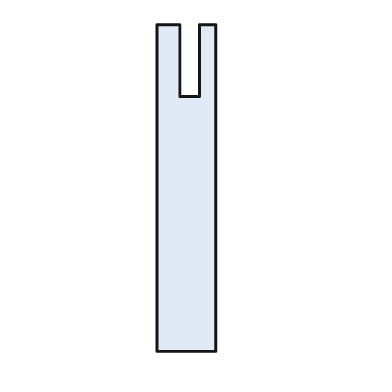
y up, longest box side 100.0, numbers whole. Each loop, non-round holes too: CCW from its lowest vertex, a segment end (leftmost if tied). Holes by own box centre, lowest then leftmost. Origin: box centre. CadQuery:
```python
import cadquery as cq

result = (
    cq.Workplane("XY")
    .moveTo(-9.0, -50.0)
    .lineTo(9.0, -50.0)
    .lineTo(9.0, 50.0)
    .lineTo(4.0, 50.0)
    .lineTo(4.0, 28.0)
    .lineTo(-2.0, 28.0)
    .lineTo(-2.0, 50.0)
    .lineTo(-9.0, 50.0)
    .close()
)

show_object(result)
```